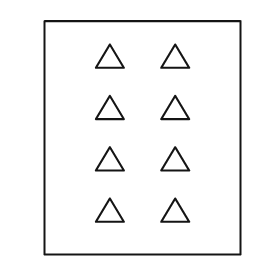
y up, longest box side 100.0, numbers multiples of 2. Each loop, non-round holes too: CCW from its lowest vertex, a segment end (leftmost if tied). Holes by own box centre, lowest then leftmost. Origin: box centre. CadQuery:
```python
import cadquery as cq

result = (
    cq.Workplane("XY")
    .moveTo(-42.0, -50.0)
    .lineTo(42.0, -50.0)
    .lineTo(42.0, 50.0)
    .lineTo(-42.0, 50.0)
    .close()
    .moveTo(-20.0, -36.0)
    .lineTo(-8.0, -36.0)
    .lineTo(-14.0, -26.0)
    .close()
    .moveTo(8.0, -36.0)
    .lineTo(20.0, -36.0)
    .lineTo(14.0, -26.0)
    .close()
    .moveTo(-20.0, -14.0)
    .lineTo(-8.0, -14.0)
    .lineTo(-14.0, -4.0)
    .close()
    .moveTo(8.0, -14.0)
    .lineTo(20.0, -14.0)
    .lineTo(14.0, -4.0)
    .close()
    .moveTo(-20.0, 8.0)
    .lineTo(-8.0, 8.0)
    .lineTo(-14.0, 18.0)
    .close()
    .moveTo(8.0, 8.0)
    .lineTo(20.0, 8.0)
    .lineTo(14.0, 18.0)
    .close()
    .moveTo(-20.0, 30.0)
    .lineTo(-8.0, 30.0)
    .lineTo(-14.0, 40.0)
    .close()
    .moveTo(8.0, 30.0)
    .lineTo(20.0, 30.0)
    .lineTo(14.0, 40.0)
    .close()
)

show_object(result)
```